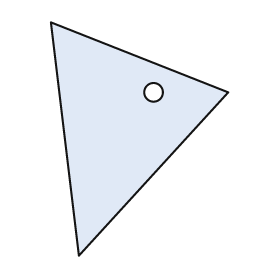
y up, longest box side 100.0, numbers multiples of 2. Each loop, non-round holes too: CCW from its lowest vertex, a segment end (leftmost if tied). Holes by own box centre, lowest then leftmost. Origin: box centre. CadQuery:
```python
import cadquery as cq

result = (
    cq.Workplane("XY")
    .moveTo(-26.0, -50.0)
    .lineTo(38.0, 20.0)
    .lineTo(-38.0, 50.0)
    .close()
    .moveTo(6.0, 20.0)
    .circle(4.0)
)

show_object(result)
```